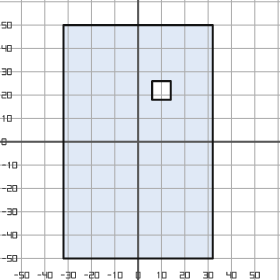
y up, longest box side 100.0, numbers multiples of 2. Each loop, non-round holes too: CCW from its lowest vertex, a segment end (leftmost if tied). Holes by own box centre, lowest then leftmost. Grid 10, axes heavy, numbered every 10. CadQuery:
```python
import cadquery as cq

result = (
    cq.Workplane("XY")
    .moveTo(-32.0, -50.0)
    .lineTo(32.0, -50.0)
    .lineTo(32.0, 50.0)
    .lineTo(-32.0, 50.0)
    .close()
    .moveTo(6.0, 18.0)
    .lineTo(14.0, 18.0)
    .lineTo(14.0, 26.0)
    .lineTo(6.0, 26.0)
    .close()
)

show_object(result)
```